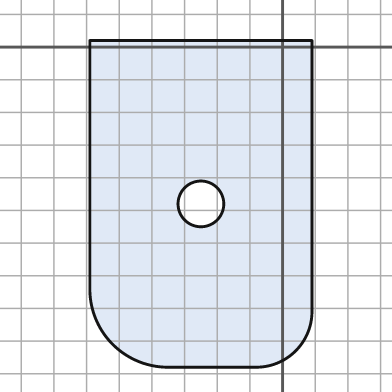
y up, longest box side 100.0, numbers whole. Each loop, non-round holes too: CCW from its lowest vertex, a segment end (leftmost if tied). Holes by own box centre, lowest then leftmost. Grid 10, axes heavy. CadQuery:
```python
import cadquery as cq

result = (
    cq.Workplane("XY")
    .moveTo(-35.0, -98.0)
    .lineTo(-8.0, -98.0)
    .threePointArc((4.0, -93.0), (9.0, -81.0))
    .lineTo(9.0, 2.0)
    .lineTo(-59.0, 2.0)
    .lineTo(-59.0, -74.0)
    .threePointArc((-52.0, -91.0), (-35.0, -98.0))
    .close()
    .moveTo(-25.0, -48.0)
    .circle(7.0)
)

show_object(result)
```